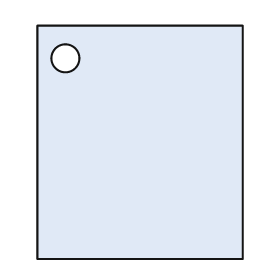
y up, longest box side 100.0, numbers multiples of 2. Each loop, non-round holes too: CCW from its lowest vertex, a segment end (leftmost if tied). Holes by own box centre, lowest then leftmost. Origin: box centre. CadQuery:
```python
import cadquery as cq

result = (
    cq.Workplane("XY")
    .moveTo(-44.0, -50.0)
    .lineTo(44.0, -50.0)
    .lineTo(44.0, 50.0)
    .lineTo(-44.0, 50.0)
    .close()
    .moveTo(-32.0, 36.0)
    .circle(6.0)
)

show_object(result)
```